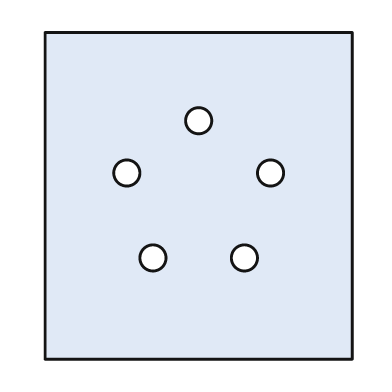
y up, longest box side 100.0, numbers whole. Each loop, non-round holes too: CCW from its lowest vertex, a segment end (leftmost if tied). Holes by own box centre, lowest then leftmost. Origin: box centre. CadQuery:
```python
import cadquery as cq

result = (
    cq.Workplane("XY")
    .moveTo(-47.0, -50.0)
    .lineTo(47.0, -50.0)
    .lineTo(47.0, 50.0)
    .lineTo(-47.0, 50.0)
    .close()
    .moveTo(-14.0, -19.0)
    .circle(4.0)
    .moveTo(14.0, -19.0)
    .circle(4.0)
    .moveTo(-22.0, 7.0)
    .circle(4.0)
    .moveTo(22.0, 7.0)
    .circle(4.0)
    .moveTo(0.0, 23.0)
    .circle(4.0)
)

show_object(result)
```